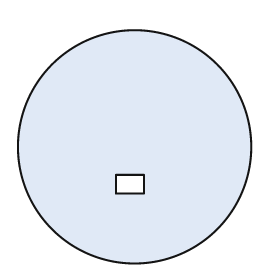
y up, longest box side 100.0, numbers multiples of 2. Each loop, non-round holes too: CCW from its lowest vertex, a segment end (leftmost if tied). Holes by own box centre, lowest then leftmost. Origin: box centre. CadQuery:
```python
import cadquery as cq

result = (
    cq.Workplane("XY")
    .moveTo(0.0, 0.0)
    .circle(50.0)
    .moveTo(-8.0, -20.0)
    .lineTo(4.0, -20.0)
    .lineTo(4.0, -12.0)
    .lineTo(-8.0, -12.0)
    .close()
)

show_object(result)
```